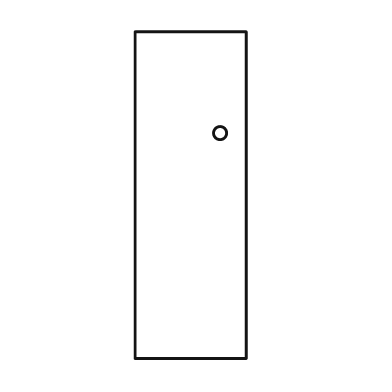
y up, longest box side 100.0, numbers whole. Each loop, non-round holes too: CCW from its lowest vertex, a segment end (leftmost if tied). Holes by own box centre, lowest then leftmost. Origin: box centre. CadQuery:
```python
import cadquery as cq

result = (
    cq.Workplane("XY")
    .moveTo(-17.0, -50.0)
    .lineTo(17.0, -50.0)
    .lineTo(17.0, 50.0)
    .lineTo(-17.0, 50.0)
    .close()
    .moveTo(9.0, 19.0)
    .circle(2.0)
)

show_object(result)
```